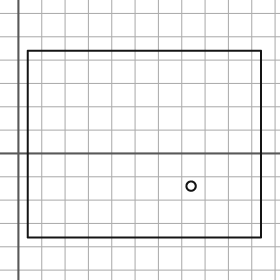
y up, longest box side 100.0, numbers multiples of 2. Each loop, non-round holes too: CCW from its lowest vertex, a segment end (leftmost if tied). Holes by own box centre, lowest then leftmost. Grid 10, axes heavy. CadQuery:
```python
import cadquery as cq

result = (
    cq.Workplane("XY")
    .moveTo(4.0, -36.0)
    .lineTo(104.0, -36.0)
    .lineTo(104.0, 44.0)
    .lineTo(4.0, 44.0)
    .close()
    .moveTo(74.0, -14.0)
    .circle(2.0)
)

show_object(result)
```